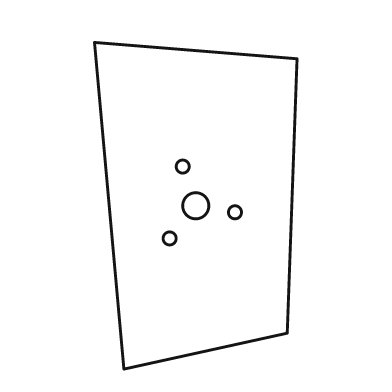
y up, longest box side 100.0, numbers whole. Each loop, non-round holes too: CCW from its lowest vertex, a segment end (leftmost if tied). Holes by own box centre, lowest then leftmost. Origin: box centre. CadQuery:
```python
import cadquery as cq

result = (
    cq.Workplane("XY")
    .moveTo(-22.0, -50.0)
    .lineTo(28.0, -39.0)
    .lineTo(31.0, 45.0)
    .lineTo(-31.0, 50.0)
    .close()
    .moveTo(-8.0, -10.0)
    .circle(2.0)
    .moveTo(12.0, -2.0)
    .circle(2.0)
    .moveTo(0.0, 0.0)
    .circle(4.0)
    .moveTo(-4.0, 12.0)
    .circle(2.0)
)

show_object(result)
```